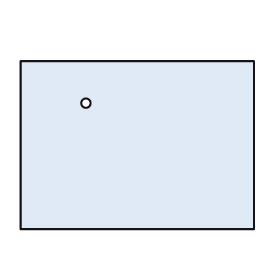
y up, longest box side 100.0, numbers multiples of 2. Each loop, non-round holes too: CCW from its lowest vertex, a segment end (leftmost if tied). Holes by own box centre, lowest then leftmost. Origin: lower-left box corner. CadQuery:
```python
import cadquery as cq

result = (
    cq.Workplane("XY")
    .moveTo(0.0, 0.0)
    .lineTo(100.0, 0.0)
    .lineTo(100.0, 72.0)
    .lineTo(0.0, 72.0)
    .close()
    .moveTo(28.0, 54.0)
    .circle(2.0)
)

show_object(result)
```